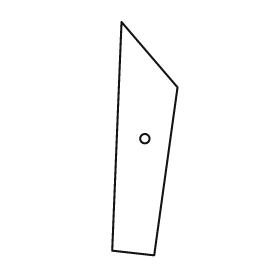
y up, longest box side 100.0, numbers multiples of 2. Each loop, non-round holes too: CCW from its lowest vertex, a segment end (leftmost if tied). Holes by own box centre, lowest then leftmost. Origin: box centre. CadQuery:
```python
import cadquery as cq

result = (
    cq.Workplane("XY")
    .moveTo(4.0, -50.0)
    .lineTo(14.0, 22.0)
    .lineTo(-10.0, 50.0)
    .lineTo(-14.0, -48.0)
    .close()
    .moveTo(0.0, 0.0)
    .circle(2.0)
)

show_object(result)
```